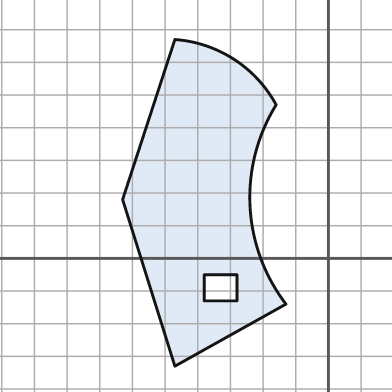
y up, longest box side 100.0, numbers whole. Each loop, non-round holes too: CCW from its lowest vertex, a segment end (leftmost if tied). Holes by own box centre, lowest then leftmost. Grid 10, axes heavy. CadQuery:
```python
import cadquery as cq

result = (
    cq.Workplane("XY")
    .moveTo(-47.0, -33.0)
    .lineTo(-13.0, -14.0)
    .threePointArc((-24.0, 16.0), (-16.0, 47.0))
    .threePointArc((-29.0, 61.0), (-47.0, 67.0))
    .lineTo(-63.0, 18.0)
    .close()
    .moveTo(-38.0, -13.0)
    .lineTo(-28.0, -13.0)
    .lineTo(-28.0, -5.0)
    .lineTo(-38.0, -5.0)
    .close()
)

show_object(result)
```